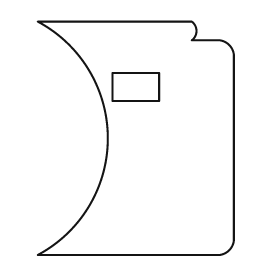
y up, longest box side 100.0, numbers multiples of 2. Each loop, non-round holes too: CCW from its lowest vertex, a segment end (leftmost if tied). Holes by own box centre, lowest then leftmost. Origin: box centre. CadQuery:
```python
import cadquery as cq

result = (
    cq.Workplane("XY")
    .moveTo(-42.0, -50.0)
    .lineTo(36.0, -50.0)
    .threePointArc((40.0, -48.0), (42.0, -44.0))
    .lineTo(42.0, 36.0)
    .threePointArc((40.0, 40.0), (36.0, 42.0))
    .lineTo(24.0, 42.0)
    .threePointArc((26.0, 46.0), (24.0, 50.0))
    .lineTo(-42.0, 50.0)
    .threePointArc((-12.0, 0.0), (-42.0, -50.0))
    .close()
    .moveTo(-10.0, 16.0)
    .lineTo(10.0, 16.0)
    .lineTo(10.0, 28.0)
    .lineTo(-10.0, 28.0)
    .close()
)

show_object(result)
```